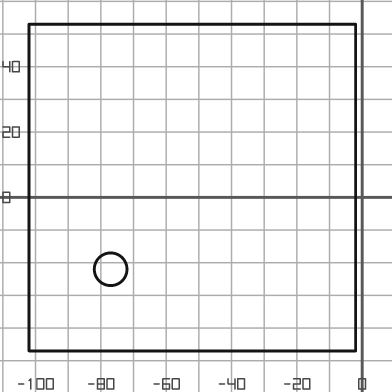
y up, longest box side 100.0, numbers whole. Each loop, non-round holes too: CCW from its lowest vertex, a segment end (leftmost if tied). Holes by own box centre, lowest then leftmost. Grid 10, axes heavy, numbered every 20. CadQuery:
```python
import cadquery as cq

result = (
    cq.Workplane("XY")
    .moveTo(-102.0, -47.0)
    .lineTo(-2.0, -47.0)
    .lineTo(-2.0, 53.0)
    .lineTo(-102.0, 53.0)
    .close()
    .moveTo(-77.0, -22.0)
    .circle(5.0)
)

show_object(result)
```